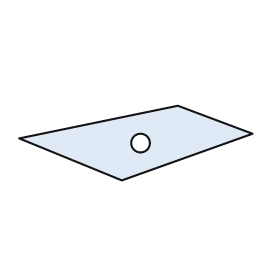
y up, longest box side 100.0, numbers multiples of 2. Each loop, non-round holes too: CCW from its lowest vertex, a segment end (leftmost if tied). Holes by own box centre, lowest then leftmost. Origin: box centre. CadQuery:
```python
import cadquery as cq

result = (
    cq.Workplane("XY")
    .moveTo(-6.0, -16.0)
    .lineTo(50.0, 4.0)
    .lineTo(18.0, 16.0)
    .lineTo(-50.0, 2.0)
    .close()
    .moveTo(2.0, 0.0)
    .circle(4.0)
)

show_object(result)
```